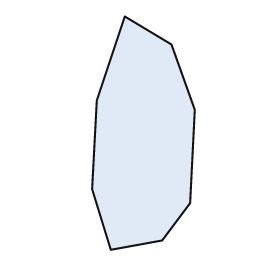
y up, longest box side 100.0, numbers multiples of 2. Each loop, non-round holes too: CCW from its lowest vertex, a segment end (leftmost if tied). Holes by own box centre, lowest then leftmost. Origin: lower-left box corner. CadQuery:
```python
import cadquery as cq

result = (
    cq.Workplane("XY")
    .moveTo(8.0, 0.0)
    .lineTo(30.0, 4.0)
    .lineTo(42.0, 20.0)
    .lineTo(44.0, 60.0)
    .lineTo(34.0, 88.0)
    .lineTo(14.0, 100.0)
    .lineTo(2.0, 64.0)
    .lineTo(0.0, 26.0)
    .close()
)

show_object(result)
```